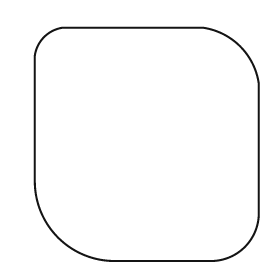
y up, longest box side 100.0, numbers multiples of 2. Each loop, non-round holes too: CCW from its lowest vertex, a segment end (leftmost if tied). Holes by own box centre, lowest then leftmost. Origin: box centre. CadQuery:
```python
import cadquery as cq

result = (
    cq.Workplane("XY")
    .moveTo(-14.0, -50.0)
    .lineTo(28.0, -50.0)
    .threePointArc((42.0, -44.0), (48.0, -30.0))
    .lineTo(48.0, 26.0)
    .threePointArc((40.0, 42.0), (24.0, 50.0))
    .lineTo(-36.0, 50.0)
    .threePointArc((-44.0, 46.0), (-48.0, 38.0))
    .lineTo(-48.0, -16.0)
    .threePointArc((-38.0, -40.0), (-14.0, -50.0))
    .close()
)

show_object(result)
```